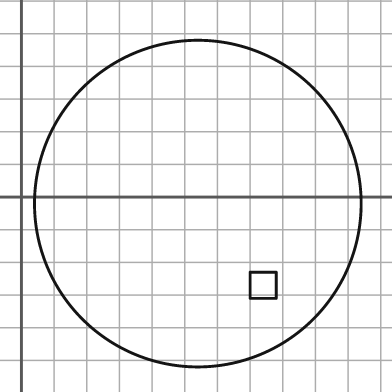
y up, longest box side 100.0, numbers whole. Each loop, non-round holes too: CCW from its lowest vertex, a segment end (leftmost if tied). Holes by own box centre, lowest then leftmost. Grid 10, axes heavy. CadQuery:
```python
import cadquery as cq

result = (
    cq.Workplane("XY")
    .moveTo(54.0, -2.0)
    .circle(50.0)
    .moveTo(70.0, -31.0)
    .lineTo(78.0, -31.0)
    .lineTo(78.0, -23.0)
    .lineTo(70.0, -23.0)
    .close()
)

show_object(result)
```